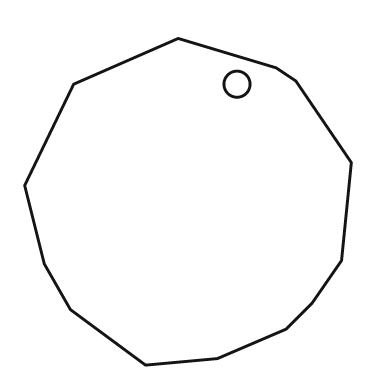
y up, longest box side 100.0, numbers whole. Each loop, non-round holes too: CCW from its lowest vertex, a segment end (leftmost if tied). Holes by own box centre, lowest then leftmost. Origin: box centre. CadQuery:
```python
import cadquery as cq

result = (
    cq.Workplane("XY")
    .moveTo(-13.0, -50.0)
    .lineTo(9.0, -48.0)
    .lineTo(30.0, -39.0)
    .lineTo(38.0, -31.0)
    .lineTo(47.0, -18.0)
    .lineTo(50.0, 12.0)
    .lineTo(33.0, 37.0)
    .lineTo(27.0, 41.0)
    .lineTo(-3.0, 50.0)
    .lineTo(-35.0, 36.0)
    .lineTo(-50.0, 5.0)
    .lineTo(-44.0, -19.0)
    .lineTo(-36.0, -33.0)
    .close()
    .moveTo(15.0, 36.0)
    .circle(4.0)
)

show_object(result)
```